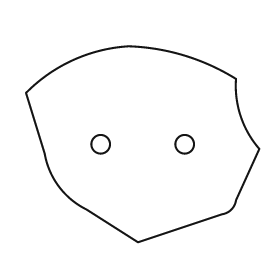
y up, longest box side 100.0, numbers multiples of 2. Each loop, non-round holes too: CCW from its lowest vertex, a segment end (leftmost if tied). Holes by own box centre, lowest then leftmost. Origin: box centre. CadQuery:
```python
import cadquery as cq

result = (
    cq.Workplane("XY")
    .moveTo(-2.0, -42.0)
    .lineTo(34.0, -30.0)
    .threePointArc((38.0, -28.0), (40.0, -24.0))
    .lineTo(50.0, -2.0)
    .threePointArc((42.0, 12.0), (40.0, 28.0))
    .threePointArc((18.0, 38.0), (-6.0, 42.0))
    .threePointArc((-30.0, 36.0), (-50.0, 22.0))
    .lineTo(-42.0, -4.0)
    .threePointArc((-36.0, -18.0), (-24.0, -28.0))
    .close()
    .moveTo(-18.0, 0.0)
    .circle(4.0)
    .moveTo(18.0, 0.0)
    .circle(4.0)
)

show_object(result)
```